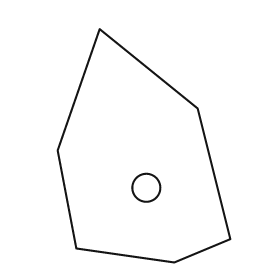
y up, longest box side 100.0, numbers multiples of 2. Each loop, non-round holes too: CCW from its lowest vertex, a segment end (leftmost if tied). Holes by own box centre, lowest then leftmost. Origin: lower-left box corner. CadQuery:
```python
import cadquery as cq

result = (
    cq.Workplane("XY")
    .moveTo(50.0, 0.0)
    .lineTo(74.0, 10.0)
    .lineTo(60.0, 66.0)
    .lineTo(18.0, 100.0)
    .lineTo(0.0, 48.0)
    .lineTo(8.0, 6.0)
    .close()
    .moveTo(38.0, 32.0)
    .circle(6.0)
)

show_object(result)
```